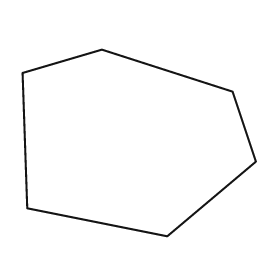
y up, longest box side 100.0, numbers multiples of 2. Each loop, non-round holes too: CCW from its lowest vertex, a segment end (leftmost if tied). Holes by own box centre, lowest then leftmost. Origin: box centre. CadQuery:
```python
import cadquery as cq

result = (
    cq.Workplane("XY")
    .moveTo(12.0, -40.0)
    .lineTo(50.0, -8.0)
    .lineTo(40.0, 22.0)
    .lineTo(-16.0, 40.0)
    .lineTo(-50.0, 30.0)
    .lineTo(-48.0, -28.0)
    .close()
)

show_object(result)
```